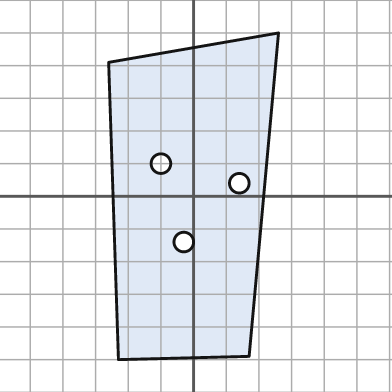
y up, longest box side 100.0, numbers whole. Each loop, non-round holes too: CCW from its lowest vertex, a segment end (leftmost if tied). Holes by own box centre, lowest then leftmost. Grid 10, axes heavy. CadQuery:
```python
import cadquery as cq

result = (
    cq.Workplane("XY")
    .moveTo(-23.0, -50.0)
    .lineTo(17.0, -49.0)
    .lineTo(26.0, 50.0)
    .lineTo(-26.0, 41.0)
    .close()
    .moveTo(-3.0, -14.0)
    .circle(3.0)
    .moveTo(14.0, 4.0)
    .circle(3.0)
    .moveTo(-10.0, 10.0)
    .circle(3.0)
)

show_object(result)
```